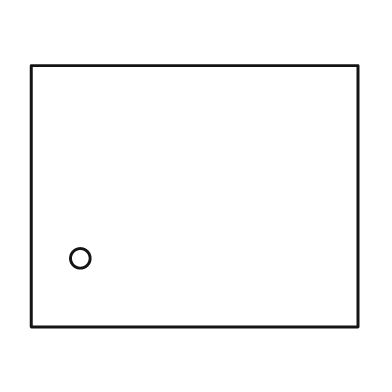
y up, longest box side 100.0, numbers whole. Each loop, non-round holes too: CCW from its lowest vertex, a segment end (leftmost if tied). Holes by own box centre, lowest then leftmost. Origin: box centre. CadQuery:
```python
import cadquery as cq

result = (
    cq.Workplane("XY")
    .moveTo(-50.0, -40.0)
    .lineTo(50.0, -40.0)
    .lineTo(50.0, 40.0)
    .lineTo(-50.0, 40.0)
    .close()
    .moveTo(-35.0, -19.0)
    .circle(3.0)
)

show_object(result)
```